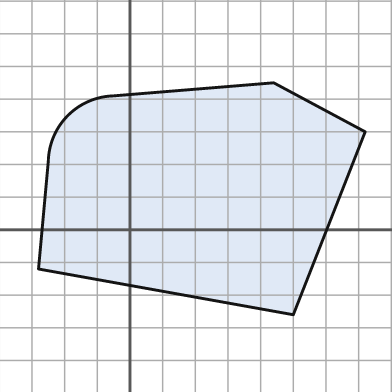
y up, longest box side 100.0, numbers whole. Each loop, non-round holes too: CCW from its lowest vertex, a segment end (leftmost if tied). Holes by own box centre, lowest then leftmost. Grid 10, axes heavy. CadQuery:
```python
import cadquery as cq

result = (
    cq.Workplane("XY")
    .moveTo(50.0, -26.0)
    .lineTo(72.0, 30.0)
    .lineTo(44.0, 45.0)
    .lineTo(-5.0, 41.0)
    .threePointArc((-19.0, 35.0), (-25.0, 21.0))
    .lineTo(-28.0, -12.0)
    .close()
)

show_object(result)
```